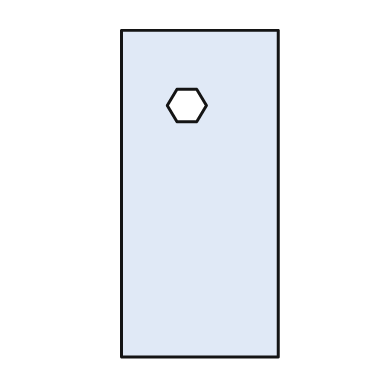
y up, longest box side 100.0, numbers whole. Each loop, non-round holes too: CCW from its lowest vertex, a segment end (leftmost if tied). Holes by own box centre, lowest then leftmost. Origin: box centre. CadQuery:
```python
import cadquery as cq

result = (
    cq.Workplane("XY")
    .moveTo(-24.0, -50.0)
    .lineTo(24.0, -50.0)
    .lineTo(24.0, 50.0)
    .lineTo(-24.0, 50.0)
    .close()
    .moveTo(-7.0, 22.0)
    .lineTo(-1.0, 22.0)
    .lineTo(2.0, 27.0)
    .lineTo(-1.0, 32.0)
    .lineTo(-7.0, 32.0)
    .lineTo(-10.0, 27.0)
    .close()
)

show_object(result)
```